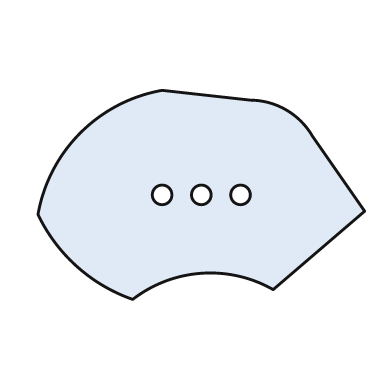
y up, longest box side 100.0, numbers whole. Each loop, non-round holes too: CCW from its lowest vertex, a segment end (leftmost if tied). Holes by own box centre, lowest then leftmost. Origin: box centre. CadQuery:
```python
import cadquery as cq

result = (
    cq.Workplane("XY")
    .moveTo(-21.0, -32.0)
    .threePointArc((0.0, -24.0), (22.0, -29.0))
    .lineTo(50.0, -5.0)
    .lineTo(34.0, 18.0)
    .threePointArc((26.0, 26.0), (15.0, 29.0))
    .lineTo(-12.0, 32.0)
    .threePointArc((-37.0, 19.0), (-50.0, -6.0))
    .threePointArc((-38.0, -22.0), (-21.0, -32.0))
    .close()
    .moveTo(-12.0, 0.0)
    .circle(3.0)
    .moveTo(0.0, 0.0)
    .circle(3.0)
    .moveTo(12.0, 0.0)
    .circle(3.0)
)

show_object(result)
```